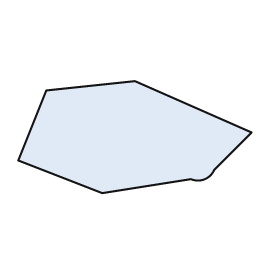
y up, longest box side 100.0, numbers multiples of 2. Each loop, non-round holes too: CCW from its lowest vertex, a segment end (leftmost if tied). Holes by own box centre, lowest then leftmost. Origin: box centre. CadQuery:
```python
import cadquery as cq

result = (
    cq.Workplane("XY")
    .moveTo(-14.0, -24.0)
    .lineTo(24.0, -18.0)
    .threePointArc((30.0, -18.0), (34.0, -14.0))
    .lineTo(50.0, 2.0)
    .lineTo(0.0, 24.0)
    .lineTo(-38.0, 20.0)
    .lineTo(-50.0, -10.0)
    .close()
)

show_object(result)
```